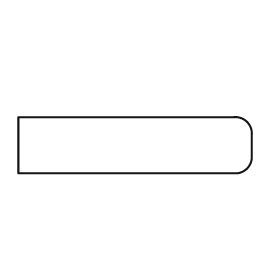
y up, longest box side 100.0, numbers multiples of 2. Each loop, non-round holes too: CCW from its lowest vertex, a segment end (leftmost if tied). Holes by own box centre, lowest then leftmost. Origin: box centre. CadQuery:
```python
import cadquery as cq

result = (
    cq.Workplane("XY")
    .moveTo(-50.0, -12.0)
    .lineTo(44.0, -12.0)
    .threePointArc((48.0, -10.0), (50.0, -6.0))
    .lineTo(50.0, 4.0)
    .threePointArc((48.0, 10.0), (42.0, 12.0))
    .lineTo(-50.0, 12.0)
    .close()
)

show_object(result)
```